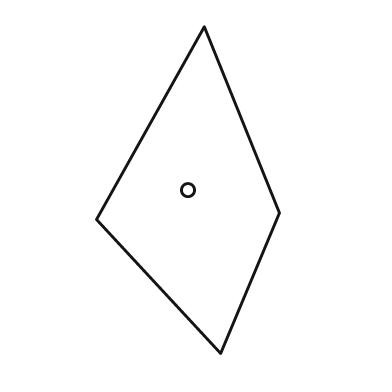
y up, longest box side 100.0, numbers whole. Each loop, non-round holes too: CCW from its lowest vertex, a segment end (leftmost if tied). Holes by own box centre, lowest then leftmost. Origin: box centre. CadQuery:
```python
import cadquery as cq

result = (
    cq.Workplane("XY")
    .moveTo(10.0, -50.0)
    .lineTo(28.0, -7.0)
    .lineTo(5.0, 50.0)
    .lineTo(-28.0, -9.0)
    .close()
    .moveTo(0.0, 0.0)
    .circle(2.0)
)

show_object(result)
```